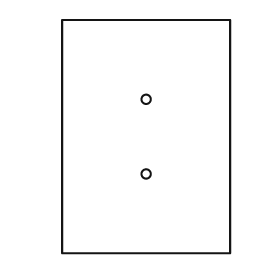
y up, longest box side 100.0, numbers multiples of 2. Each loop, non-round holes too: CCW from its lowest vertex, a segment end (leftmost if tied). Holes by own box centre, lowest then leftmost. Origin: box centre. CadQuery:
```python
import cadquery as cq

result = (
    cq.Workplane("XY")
    .moveTo(-36.0, -50.0)
    .lineTo(36.0, -50.0)
    .lineTo(36.0, 50.0)
    .lineTo(-36.0, 50.0)
    .close()
    .moveTo(0.0, -16.0)
    .circle(2.0)
    .moveTo(0.0, 16.0)
    .circle(2.0)
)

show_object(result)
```